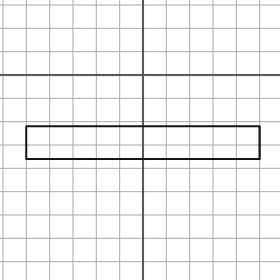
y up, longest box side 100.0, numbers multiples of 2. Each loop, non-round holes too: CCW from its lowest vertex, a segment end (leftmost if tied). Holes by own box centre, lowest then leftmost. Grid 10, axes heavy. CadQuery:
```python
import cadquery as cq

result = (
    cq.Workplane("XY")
    .moveTo(-50.0, -36.0)
    .lineTo(50.0, -36.0)
    .lineTo(50.0, -22.0)
    .lineTo(-50.0, -22.0)
    .close()
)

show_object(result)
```